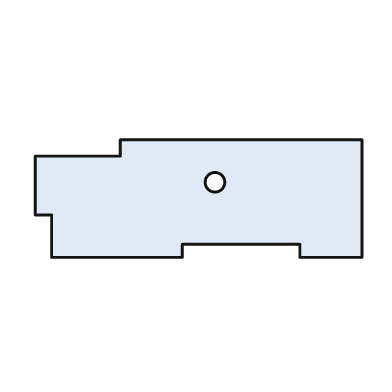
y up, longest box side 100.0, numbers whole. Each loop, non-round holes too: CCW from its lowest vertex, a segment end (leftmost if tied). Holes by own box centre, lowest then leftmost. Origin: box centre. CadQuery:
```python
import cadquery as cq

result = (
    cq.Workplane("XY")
    .moveTo(-45.0, -18.0)
    .lineTo(-5.0, -18.0)
    .lineTo(-5.0, -14.0)
    .lineTo(31.0, -14.0)
    .lineTo(31.0, -18.0)
    .lineTo(50.0, -18.0)
    .lineTo(50.0, 18.0)
    .lineTo(-24.0, 18.0)
    .lineTo(-24.0, 13.0)
    .lineTo(-50.0, 13.0)
    .lineTo(-50.0, -5.0)
    .lineTo(-45.0, -5.0)
    .close()
    .moveTo(5.0, 5.0)
    .circle(3.0)
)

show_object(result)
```